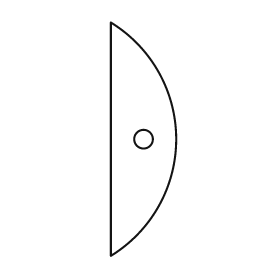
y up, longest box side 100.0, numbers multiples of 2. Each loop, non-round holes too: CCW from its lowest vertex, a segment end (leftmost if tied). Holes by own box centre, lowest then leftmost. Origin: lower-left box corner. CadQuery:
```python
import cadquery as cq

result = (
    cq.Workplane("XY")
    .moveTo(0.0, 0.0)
    .threePointArc((28.0, 50.0), (0.0, 100.0))
    .close()
    .moveTo(14.0, 50.0)
    .circle(4.0)
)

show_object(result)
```